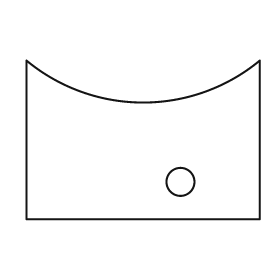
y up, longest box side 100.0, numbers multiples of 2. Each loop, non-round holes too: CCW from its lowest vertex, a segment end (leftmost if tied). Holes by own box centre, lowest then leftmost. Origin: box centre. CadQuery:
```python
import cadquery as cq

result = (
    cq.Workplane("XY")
    .moveTo(-50.0, -34.0)
    .lineTo(50.0, -34.0)
    .lineTo(50.0, 34.0)
    .threePointArc((0.0, 16.0), (-50.0, 34.0))
    .close()
    .moveTo(16.0, -18.0)
    .circle(6.0)
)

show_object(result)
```